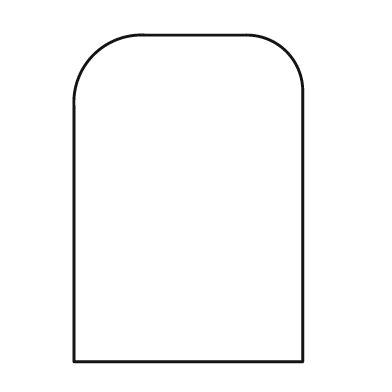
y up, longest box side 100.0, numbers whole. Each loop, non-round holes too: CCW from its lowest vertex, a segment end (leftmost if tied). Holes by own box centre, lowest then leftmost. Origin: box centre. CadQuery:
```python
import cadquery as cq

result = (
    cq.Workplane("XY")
    .moveTo(-35.0, -50.0)
    .lineTo(35.0, -50.0)
    .lineTo(35.0, 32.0)
    .threePointArc((30.0, 45.0), (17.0, 50.0))
    .lineTo(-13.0, 50.0)
    .threePointArc((-29.0, 44.0), (-35.0, 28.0))
    .close()
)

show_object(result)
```